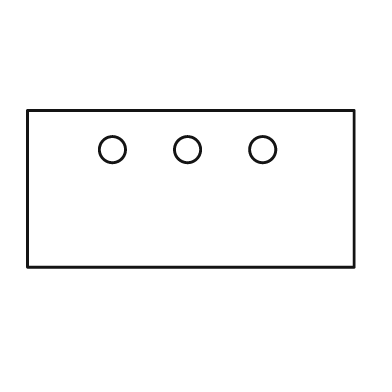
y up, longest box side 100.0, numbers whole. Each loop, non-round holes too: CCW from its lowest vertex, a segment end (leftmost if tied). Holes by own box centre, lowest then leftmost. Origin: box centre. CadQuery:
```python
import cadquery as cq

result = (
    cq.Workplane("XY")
    .moveTo(-50.0, -24.0)
    .lineTo(50.0, -24.0)
    .lineTo(50.0, 24.0)
    .lineTo(-50.0, 24.0)
    .close()
    .moveTo(-24.0, 12.0)
    .circle(4.0)
    .moveTo(-1.0, 12.0)
    .circle(4.0)
    .moveTo(22.0, 12.0)
    .circle(4.0)
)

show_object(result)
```